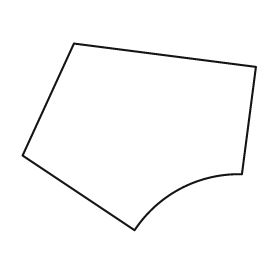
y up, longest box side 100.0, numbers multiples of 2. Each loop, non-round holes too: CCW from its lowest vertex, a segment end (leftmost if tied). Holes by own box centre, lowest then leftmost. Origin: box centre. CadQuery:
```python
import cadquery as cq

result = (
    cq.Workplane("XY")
    .moveTo(-2.0, -40.0)
    .threePointArc((18.0, -22.0), (44.0, -16.0))
    .lineTo(50.0, 30.0)
    .lineTo(-28.0, 40.0)
    .lineTo(-50.0, -8.0)
    .close()
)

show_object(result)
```